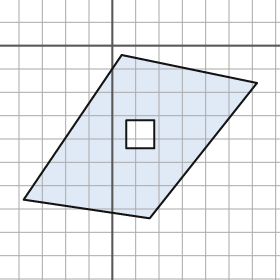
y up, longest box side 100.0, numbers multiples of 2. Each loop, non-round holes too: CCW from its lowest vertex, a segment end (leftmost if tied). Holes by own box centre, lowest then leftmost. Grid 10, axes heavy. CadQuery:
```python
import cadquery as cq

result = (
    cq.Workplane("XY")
    .moveTo(16.0, -74.0)
    .lineTo(62.0, -16.0)
    .lineTo(4.0, -4.0)
    .lineTo(-38.0, -66.0)
    .close()
    .moveTo(6.0, -44.0)
    .lineTo(18.0, -44.0)
    .lineTo(18.0, -32.0)
    .lineTo(6.0, -32.0)
    .close()
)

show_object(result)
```